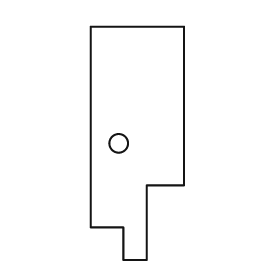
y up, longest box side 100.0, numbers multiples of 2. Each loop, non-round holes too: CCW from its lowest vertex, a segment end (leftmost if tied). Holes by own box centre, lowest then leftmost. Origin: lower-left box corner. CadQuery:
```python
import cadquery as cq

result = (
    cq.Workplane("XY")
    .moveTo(14.0, 0.0)
    .lineTo(24.0, 0.0)
    .lineTo(24.0, 32.0)
    .lineTo(40.0, 32.0)
    .lineTo(40.0, 100.0)
    .lineTo(0.0, 100.0)
    .lineTo(0.0, 14.0)
    .lineTo(14.0, 14.0)
    .close()
    .moveTo(12.0, 50.0)
    .circle(4.0)
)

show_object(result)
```